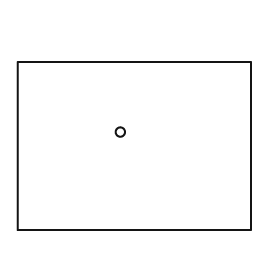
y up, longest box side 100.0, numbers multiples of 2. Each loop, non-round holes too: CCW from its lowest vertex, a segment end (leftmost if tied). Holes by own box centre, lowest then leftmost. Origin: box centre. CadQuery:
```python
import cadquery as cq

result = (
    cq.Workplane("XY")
    .moveTo(-50.0, -36.0)
    .lineTo(50.0, -36.0)
    .lineTo(50.0, 36.0)
    .lineTo(-50.0, 36.0)
    .close()
    .moveTo(-6.0, 6.0)
    .circle(2.0)
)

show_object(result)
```